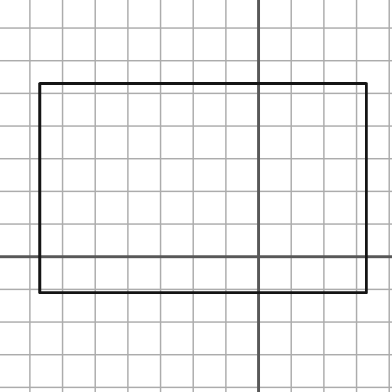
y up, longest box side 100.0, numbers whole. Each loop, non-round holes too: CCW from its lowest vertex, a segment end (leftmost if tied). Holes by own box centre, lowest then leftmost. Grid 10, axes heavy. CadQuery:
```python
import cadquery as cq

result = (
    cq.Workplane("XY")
    .moveTo(-67.0, -11.0)
    .lineTo(33.0, -11.0)
    .lineTo(33.0, 53.0)
    .lineTo(-67.0, 53.0)
    .close()
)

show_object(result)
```